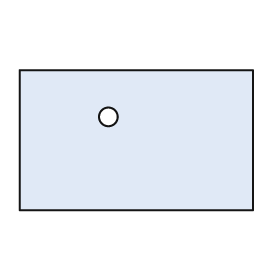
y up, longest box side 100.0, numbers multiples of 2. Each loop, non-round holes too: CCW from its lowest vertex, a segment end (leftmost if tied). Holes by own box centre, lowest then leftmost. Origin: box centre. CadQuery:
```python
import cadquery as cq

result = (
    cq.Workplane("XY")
    .moveTo(-50.0, -30.0)
    .lineTo(50.0, -30.0)
    .lineTo(50.0, 30.0)
    .lineTo(-50.0, 30.0)
    .close()
    .moveTo(-12.0, 10.0)
    .circle(4.0)
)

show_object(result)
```